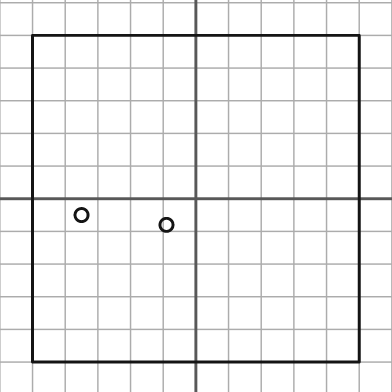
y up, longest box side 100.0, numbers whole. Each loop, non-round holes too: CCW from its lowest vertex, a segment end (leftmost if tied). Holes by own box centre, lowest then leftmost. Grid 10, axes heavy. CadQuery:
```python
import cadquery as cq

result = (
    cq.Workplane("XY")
    .moveTo(-50.0, -50.0)
    .lineTo(50.0, -50.0)
    .lineTo(50.0, 50.0)
    .lineTo(-50.0, 50.0)
    .close()
    .moveTo(-9.0, -8.0)
    .circle(2.0)
    .moveTo(-35.0, -5.0)
    .circle(2.0)
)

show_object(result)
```